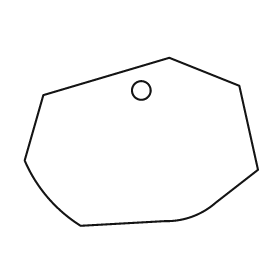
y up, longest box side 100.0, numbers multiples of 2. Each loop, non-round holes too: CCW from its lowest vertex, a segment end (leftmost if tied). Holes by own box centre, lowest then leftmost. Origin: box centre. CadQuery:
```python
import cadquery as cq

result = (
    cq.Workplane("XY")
    .moveTo(-26.0, -36.0)
    .lineTo(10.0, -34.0)
    .threePointArc((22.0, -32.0), (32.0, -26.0))
    .lineTo(50.0, -12.0)
    .lineTo(42.0, 24.0)
    .lineTo(12.0, 36.0)
    .lineTo(-42.0, 20.0)
    .lineTo(-50.0, -8.0)
    .threePointArc((-40.0, -24.0), (-26.0, -36.0))
    .close()
    .moveTo(0.0, 22.0)
    .circle(4.0)
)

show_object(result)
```